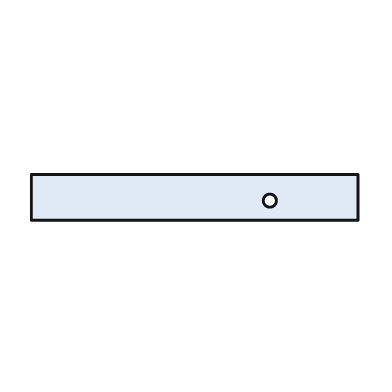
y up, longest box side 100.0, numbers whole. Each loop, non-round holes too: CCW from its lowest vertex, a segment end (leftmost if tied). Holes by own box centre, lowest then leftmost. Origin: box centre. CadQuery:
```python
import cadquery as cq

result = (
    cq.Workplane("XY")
    .moveTo(-50.0, -7.0)
    .lineTo(50.0, -7.0)
    .lineTo(50.0, 7.0)
    .lineTo(-50.0, 7.0)
    .close()
    .moveTo(23.0, -1.0)
    .circle(2.0)
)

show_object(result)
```